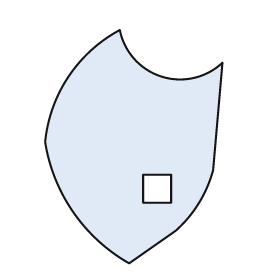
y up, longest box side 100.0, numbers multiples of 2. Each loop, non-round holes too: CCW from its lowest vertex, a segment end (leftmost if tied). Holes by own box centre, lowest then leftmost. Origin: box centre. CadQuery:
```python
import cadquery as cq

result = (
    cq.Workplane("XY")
    .moveTo(-2.0, -50.0)
    .lineTo(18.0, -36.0)
    .threePointArc((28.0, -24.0), (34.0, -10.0))
    .lineTo(38.0, 36.0)
    .threePointArc((12.0, 30.0), (-6.0, 50.0))
    .threePointArc((-28.0, 30.0), (-38.0, 2.0))
    .threePointArc((-26.0, -28.0), (-2.0, -50.0))
    .close()
    .moveTo(4.0, -24.0)
    .lineTo(16.0, -24.0)
    .lineTo(16.0, -12.0)
    .lineTo(4.0, -12.0)
    .close()
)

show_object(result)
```